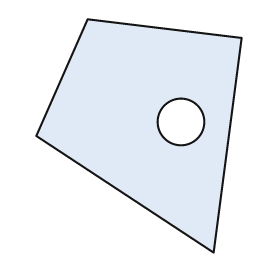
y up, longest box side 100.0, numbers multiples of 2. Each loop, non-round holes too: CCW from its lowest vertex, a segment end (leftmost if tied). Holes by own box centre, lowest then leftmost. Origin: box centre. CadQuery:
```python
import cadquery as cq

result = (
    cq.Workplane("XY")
    .moveTo(32.0, -50.0)
    .lineTo(44.0, 42.0)
    .lineTo(-22.0, 50.0)
    .lineTo(-44.0, 0.0)
    .close()
    .moveTo(18.0, 6.0)
    .circle(10.0)
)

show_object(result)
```